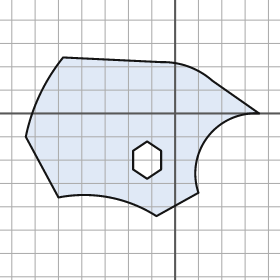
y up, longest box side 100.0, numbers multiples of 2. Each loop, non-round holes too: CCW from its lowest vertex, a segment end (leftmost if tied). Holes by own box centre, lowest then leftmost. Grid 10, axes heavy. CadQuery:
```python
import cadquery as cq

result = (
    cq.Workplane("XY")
    .moveTo(-8.0, -44.0)
    .lineTo(10.0, -34.0)
    .threePointArc((14.0, -10.0), (36.0, 0.0))
    .lineTo(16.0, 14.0)
    .threePointArc((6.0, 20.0), (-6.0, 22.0))
    .lineTo(-48.0, 24.0)
    .threePointArc((-58.0, 8.0), (-64.0, -10.0))
    .lineTo(-50.0, -36.0)
    .threePointArc((-28.0, -36.0), (-8.0, -44.0))
    .close()
    .moveTo(-12.0, -28.0)
    .lineTo(-6.0, -24.0)
    .lineTo(-6.0, -16.0)
    .lineTo(-12.0, -12.0)
    .lineTo(-18.0, -16.0)
    .lineTo(-18.0, -24.0)
    .close()
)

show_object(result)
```